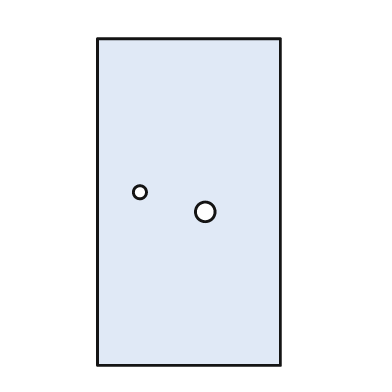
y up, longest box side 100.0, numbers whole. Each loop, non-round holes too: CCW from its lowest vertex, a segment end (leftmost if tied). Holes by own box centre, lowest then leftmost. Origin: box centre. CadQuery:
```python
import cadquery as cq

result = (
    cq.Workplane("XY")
    .moveTo(-28.0, -50.0)
    .lineTo(28.0, -50.0)
    .lineTo(28.0, 50.0)
    .lineTo(-28.0, 50.0)
    .close()
    .moveTo(5.0, -3.0)
    .circle(3.0)
    .moveTo(-15.0, 3.0)
    .circle(2.0)
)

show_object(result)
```